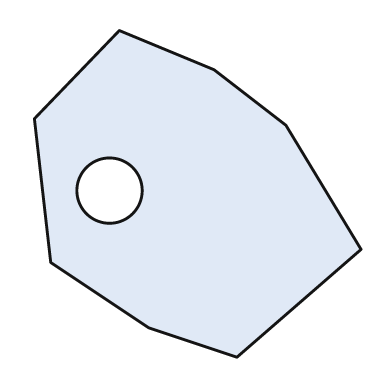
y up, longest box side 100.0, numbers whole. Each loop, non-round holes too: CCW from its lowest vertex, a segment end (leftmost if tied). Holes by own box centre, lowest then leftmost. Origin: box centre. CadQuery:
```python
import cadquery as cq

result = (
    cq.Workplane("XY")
    .moveTo(12.0, -50.0)
    .lineTo(50.0, -17.0)
    .lineTo(27.0, 21.0)
    .lineTo(5.0, 38.0)
    .lineTo(-24.0, 50.0)
    .lineTo(-50.0, 23.0)
    .lineTo(-45.0, -21.0)
    .lineTo(-15.0, -41.0)
    .close()
    .moveTo(-27.0, 1.0)
    .circle(10.0)
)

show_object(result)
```